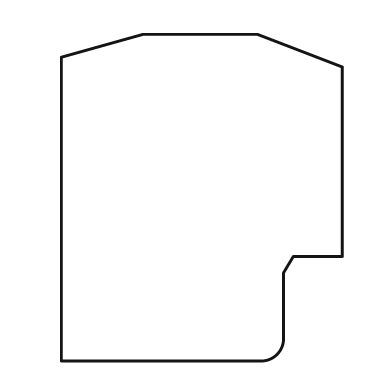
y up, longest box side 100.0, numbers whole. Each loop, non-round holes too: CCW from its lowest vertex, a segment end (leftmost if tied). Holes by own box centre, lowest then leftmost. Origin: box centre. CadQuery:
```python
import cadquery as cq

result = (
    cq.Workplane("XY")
    .moveTo(-43.0, -50.0)
    .lineTo(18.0, -50.0)
    .threePointArc((23.0, -48.0), (25.0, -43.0))
    .lineTo(25.0, -23.0)
    .lineTo(28.0, -18.0)
    .lineTo(43.0, -18.0)
    .lineTo(43.0, 40.0)
    .lineTo(17.0, 50.0)
    .lineTo(-18.0, 50.0)
    .lineTo(-43.0, 43.0)
    .close()
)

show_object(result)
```